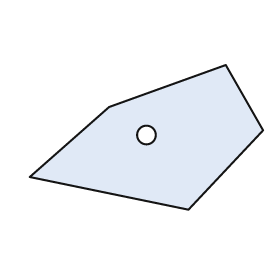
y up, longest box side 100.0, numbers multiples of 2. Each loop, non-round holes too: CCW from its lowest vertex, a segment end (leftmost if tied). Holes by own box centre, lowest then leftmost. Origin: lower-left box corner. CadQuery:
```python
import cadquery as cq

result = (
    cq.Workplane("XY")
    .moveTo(68.0, 0.0)
    .lineTo(100.0, 34.0)
    .lineTo(84.0, 62.0)
    .lineTo(34.0, 44.0)
    .lineTo(0.0, 14.0)
    .close()
    .moveTo(50.0, 32.0)
    .circle(4.0)
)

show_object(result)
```